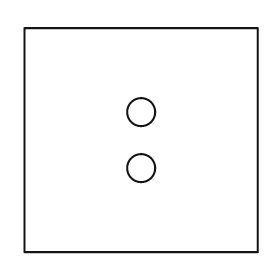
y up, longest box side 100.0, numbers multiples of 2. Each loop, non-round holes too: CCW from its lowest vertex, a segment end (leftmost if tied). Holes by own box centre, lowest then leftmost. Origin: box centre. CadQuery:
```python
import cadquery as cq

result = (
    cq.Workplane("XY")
    .moveTo(-50.0, -48.0)
    .lineTo(50.0, -48.0)
    .lineTo(50.0, 48.0)
    .lineTo(-50.0, 48.0)
    .close()
    .moveTo(0.0, -12.0)
    .circle(6.0)
    .moveTo(0.0, 12.0)
    .circle(6.0)
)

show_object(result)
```